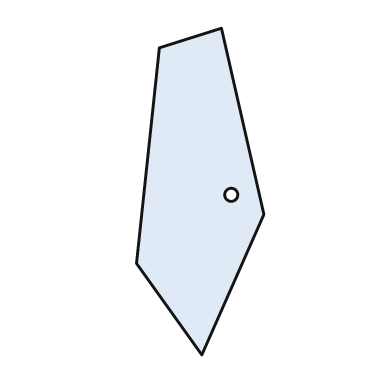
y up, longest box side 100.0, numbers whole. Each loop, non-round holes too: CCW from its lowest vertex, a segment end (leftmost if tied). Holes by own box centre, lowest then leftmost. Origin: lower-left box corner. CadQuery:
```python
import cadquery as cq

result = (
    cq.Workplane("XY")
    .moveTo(20.0, 0.0)
    .lineTo(39.0, 43.0)
    .lineTo(26.0, 100.0)
    .lineTo(7.0, 94.0)
    .lineTo(0.0, 28.0)
    .close()
    .moveTo(29.0, 49.0)
    .circle(2.0)
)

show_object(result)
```